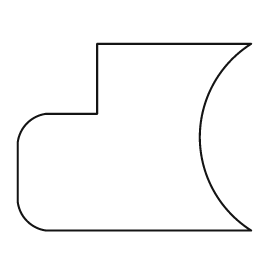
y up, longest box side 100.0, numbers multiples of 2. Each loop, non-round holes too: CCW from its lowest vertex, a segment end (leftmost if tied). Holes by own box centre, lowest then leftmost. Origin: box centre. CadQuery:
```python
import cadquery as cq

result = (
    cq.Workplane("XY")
    .moveTo(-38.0, -40.0)
    .lineTo(50.0, -40.0)
    .threePointArc((28.0, 0.0), (50.0, 40.0))
    .lineTo(-16.0, 40.0)
    .lineTo(-16.0, 10.0)
    .lineTo(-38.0, 10.0)
    .threePointArc((-46.0, 6.0), (-50.0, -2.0))
    .lineTo(-50.0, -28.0)
    .threePointArc((-46.0, -36.0), (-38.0, -40.0))
    .close()
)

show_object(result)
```